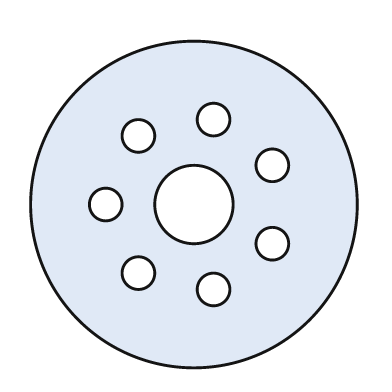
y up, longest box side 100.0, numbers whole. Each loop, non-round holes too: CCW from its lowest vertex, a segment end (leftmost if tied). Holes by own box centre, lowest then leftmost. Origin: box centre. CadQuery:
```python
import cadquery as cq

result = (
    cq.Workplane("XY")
    .moveTo(0.0, 0.0)
    .circle(50.0)
    .moveTo(6.0, -26.0)
    .circle(5.0)
    .moveTo(-17.0, -21.0)
    .circle(5.0)
    .moveTo(24.0, -12.0)
    .circle(5.0)
    .moveTo(-27.0, 0.0)
    .circle(5.0)
    .moveTo(0.0, 0.0)
    .circle(12.0)
    .moveTo(24.0, 12.0)
    .circle(5.0)
    .moveTo(-17.0, 21.0)
    .circle(5.0)
    .moveTo(6.0, 26.0)
    .circle(5.0)
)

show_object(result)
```